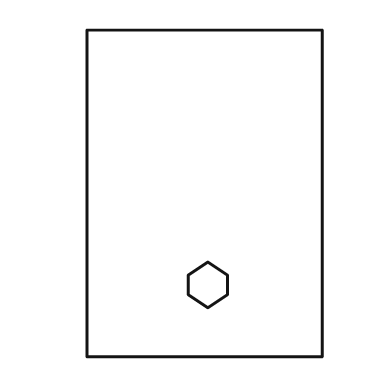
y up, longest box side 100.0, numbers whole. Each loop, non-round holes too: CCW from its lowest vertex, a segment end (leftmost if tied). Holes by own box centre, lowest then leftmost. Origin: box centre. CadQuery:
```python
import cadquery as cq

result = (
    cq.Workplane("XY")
    .moveTo(-36.0, -50.0)
    .lineTo(36.0, -50.0)
    .lineTo(36.0, 50.0)
    .lineTo(-36.0, 50.0)
    .close()
    .moveTo(1.0, -35.0)
    .lineTo(7.0, -31.0)
    .lineTo(7.0, -25.0)
    .lineTo(1.0, -21.0)
    .lineTo(-5.0, -25.0)
    .lineTo(-5.0, -31.0)
    .close()
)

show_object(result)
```